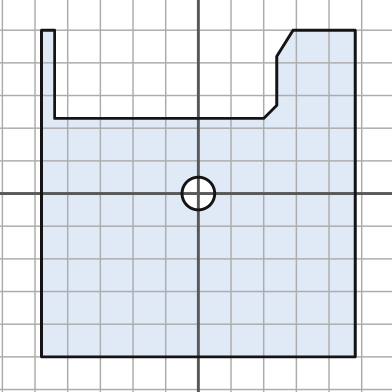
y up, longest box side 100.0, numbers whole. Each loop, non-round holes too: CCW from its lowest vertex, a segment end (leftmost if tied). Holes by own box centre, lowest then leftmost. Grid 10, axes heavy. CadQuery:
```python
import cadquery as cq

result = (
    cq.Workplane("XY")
    .moveTo(-48.0, -50.0)
    .lineTo(48.0, -50.0)
    .lineTo(48.0, 50.0)
    .lineTo(29.0, 50.0)
    .lineTo(24.0, 42.0)
    .lineTo(24.0, 27.0)
    .lineTo(20.0, 23.0)
    .lineTo(-44.0, 23.0)
    .lineTo(-44.0, 50.0)
    .lineTo(-48.0, 50.0)
    .close()
    .moveTo(0.0, 0.0)
    .circle(5.0)
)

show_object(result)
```